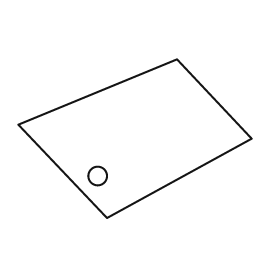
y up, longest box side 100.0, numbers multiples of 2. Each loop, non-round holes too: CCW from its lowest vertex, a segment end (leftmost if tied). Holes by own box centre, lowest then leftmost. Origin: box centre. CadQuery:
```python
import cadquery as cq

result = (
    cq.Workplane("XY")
    .moveTo(-12.0, -34.0)
    .lineTo(50.0, 0.0)
    .lineTo(18.0, 34.0)
    .lineTo(-50.0, 6.0)
    .close()
    .moveTo(-16.0, -16.0)
    .circle(4.0)
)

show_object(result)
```